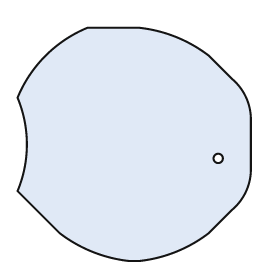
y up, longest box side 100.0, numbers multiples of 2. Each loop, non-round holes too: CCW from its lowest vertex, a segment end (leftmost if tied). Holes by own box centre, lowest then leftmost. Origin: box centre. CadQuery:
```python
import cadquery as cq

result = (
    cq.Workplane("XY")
    .moveTo(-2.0, -50.0)
    .lineTo(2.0, -50.0)
    .threePointArc((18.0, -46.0), (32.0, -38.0))
    .lineTo(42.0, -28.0)
    .threePointArc((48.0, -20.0), (50.0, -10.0))
    .lineTo(50.0, 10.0)
    .threePointArc((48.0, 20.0), (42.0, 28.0))
    .lineTo(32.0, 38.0)
    .threePointArc((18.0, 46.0), (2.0, 50.0))
    .lineTo(-20.0, 50.0)
    .threePointArc((-38.0, 38.0), (-50.0, 20.0))
    .threePointArc((-46.0, 0.0), (-50.0, -20.0))
    .lineTo(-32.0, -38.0)
    .threePointArc((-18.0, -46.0), (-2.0, -50.0))
    .close()
    .moveTo(36.0, -6.0)
    .circle(2.0)
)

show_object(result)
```